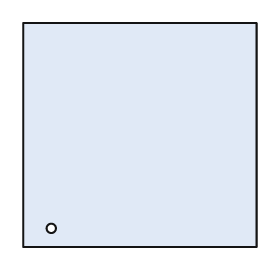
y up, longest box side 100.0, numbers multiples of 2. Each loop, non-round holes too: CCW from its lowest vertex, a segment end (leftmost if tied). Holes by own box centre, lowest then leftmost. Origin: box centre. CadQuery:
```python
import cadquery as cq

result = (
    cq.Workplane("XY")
    .moveTo(-50.0, -48.0)
    .lineTo(50.0, -48.0)
    .lineTo(50.0, 48.0)
    .lineTo(-50.0, 48.0)
    .close()
    .moveTo(-38.0, -40.0)
    .circle(2.0)
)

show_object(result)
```